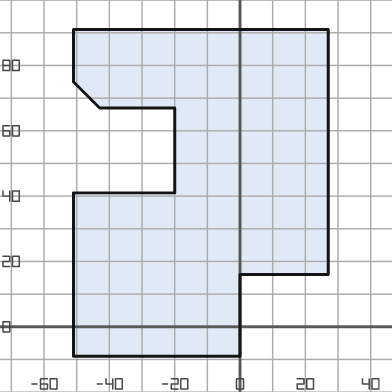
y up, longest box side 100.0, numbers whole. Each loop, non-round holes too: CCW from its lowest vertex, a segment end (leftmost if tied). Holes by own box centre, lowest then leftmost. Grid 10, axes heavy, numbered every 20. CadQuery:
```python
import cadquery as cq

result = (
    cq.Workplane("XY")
    .moveTo(-51.0, -9.0)
    .lineTo(0.0, -9.0)
    .lineTo(0.0, 16.0)
    .lineTo(27.0, 16.0)
    .lineTo(27.0, 91.0)
    .lineTo(-51.0, 91.0)
    .lineTo(-51.0, 75.0)
    .lineTo(-43.0, 67.0)
    .lineTo(-20.0, 67.0)
    .lineTo(-20.0, 41.0)
    .lineTo(-51.0, 41.0)
    .close()
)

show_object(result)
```